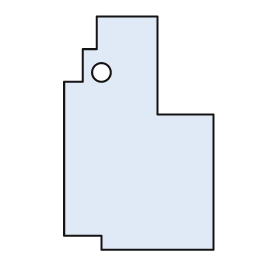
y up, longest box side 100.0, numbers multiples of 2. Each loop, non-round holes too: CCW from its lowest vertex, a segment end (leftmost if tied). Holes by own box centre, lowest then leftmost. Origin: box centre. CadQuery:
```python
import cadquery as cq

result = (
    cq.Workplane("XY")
    .moveTo(-16.0, -50.0)
    .lineTo(32.0, -50.0)
    .lineTo(32.0, 8.0)
    .lineTo(8.0, 8.0)
    .lineTo(8.0, 50.0)
    .lineTo(-18.0, 50.0)
    .lineTo(-18.0, 36.0)
    .lineTo(-24.0, 36.0)
    .lineTo(-24.0, 22.0)
    .lineTo(-32.0, 22.0)
    .lineTo(-32.0, -44.0)
    .lineTo(-16.0, -44.0)
    .close()
    .moveTo(-16.0, 26.0)
    .circle(4.0)
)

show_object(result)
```